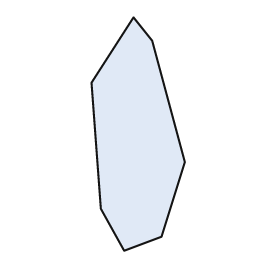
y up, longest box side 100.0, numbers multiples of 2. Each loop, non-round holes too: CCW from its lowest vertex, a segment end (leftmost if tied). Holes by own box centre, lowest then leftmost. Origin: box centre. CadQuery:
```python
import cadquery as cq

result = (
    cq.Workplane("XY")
    .moveTo(-6.0, -50.0)
    .lineTo(10.0, -44.0)
    .lineTo(20.0, -12.0)
    .lineTo(6.0, 40.0)
    .lineTo(-2.0, 50.0)
    .lineTo(-20.0, 22.0)
    .lineTo(-16.0, -32.0)
    .close()
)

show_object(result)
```